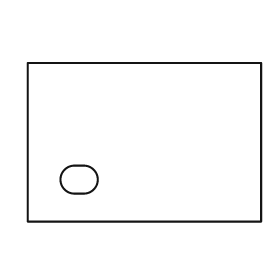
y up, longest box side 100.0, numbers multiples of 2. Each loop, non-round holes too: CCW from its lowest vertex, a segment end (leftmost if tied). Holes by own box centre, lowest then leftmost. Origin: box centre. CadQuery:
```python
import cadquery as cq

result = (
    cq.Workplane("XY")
    .moveTo(-50.0, -34.0)
    .lineTo(50.0, -34.0)
    .lineTo(50.0, 34.0)
    .lineTo(-50.0, 34.0)
    .close()
    .moveTo(-30.0, -22.0)
    .lineTo(-26.0, -22.0)
    .threePointArc((-20.0, -16.0), (-26.0, -10.0))
    .lineTo(-30.0, -10.0)
    .threePointArc((-36.0, -16.0), (-30.0, -22.0))
    .close()
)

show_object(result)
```